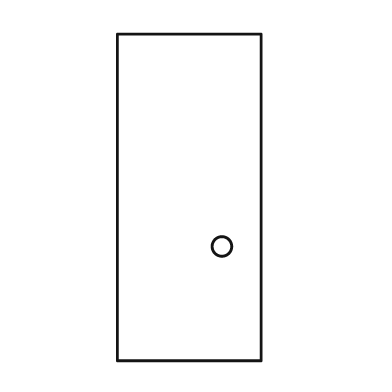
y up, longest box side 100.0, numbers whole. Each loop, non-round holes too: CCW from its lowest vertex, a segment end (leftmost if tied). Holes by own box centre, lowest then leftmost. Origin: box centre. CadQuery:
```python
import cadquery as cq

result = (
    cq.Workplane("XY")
    .moveTo(-22.0, -50.0)
    .lineTo(22.0, -50.0)
    .lineTo(22.0, 50.0)
    .lineTo(-22.0, 50.0)
    .close()
    .moveTo(10.0, -15.0)
    .circle(3.0)
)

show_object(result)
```